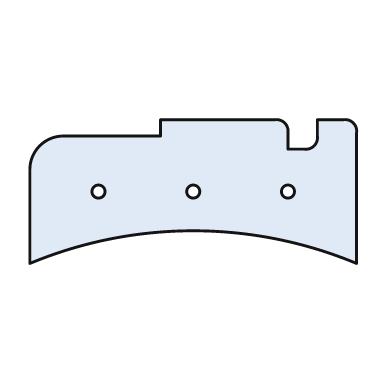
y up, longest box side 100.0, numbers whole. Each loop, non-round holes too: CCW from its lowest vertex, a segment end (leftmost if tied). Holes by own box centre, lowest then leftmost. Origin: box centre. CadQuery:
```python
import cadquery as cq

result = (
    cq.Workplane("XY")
    .moveTo(-50.0, -22.0)
    .threePointArc((0.0, -12.0), (50.0, -22.0))
    .lineTo(50.0, 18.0)
    .threePointArc((49.0, 21.0), (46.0, 22.0))
    .lineTo(38.0, 22.0)
    .lineTo(38.0, 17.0)
    .threePointArc((37.0, 14.0), (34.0, 13.0))
    .lineTo(29.0, 13.0)
    .lineTo(29.0, 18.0)
    .threePointArc((28.0, 21.0), (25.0, 22.0))
    .lineTo(-10.0, 22.0)
    .lineTo(-10.0, 17.0)
    .lineTo(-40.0, 17.0)
    .threePointArc((-47.0, 14.0), (-50.0, 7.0))
    .close()
    .moveTo(-29.0, 0.0)
    .circle(2.0)
    .moveTo(0.0, 0.0)
    .circle(2.0)
    .moveTo(29.0, 0.0)
    .circle(2.0)
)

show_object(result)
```